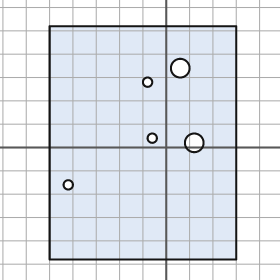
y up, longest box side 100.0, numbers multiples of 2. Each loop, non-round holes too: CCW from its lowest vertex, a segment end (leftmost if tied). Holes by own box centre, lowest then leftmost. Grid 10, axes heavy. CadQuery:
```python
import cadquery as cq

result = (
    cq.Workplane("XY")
    .moveTo(-50.0, -48.0)
    .lineTo(30.0, -48.0)
    .lineTo(30.0, 52.0)
    .lineTo(-50.0, 52.0)
    .close()
    .moveTo(-42.0, -16.0)
    .circle(2.0)
    .moveTo(12.0, 2.0)
    .circle(4.0)
    .moveTo(-6.0, 4.0)
    .circle(2.0)
    .moveTo(-8.0, 28.0)
    .circle(2.0)
    .moveTo(6.0, 34.0)
    .circle(4.0)
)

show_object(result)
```